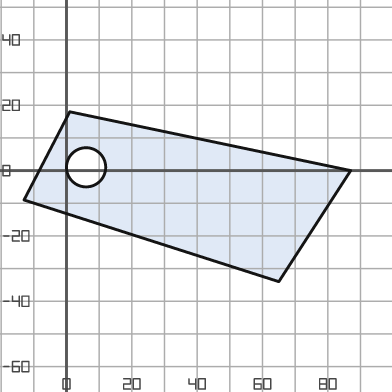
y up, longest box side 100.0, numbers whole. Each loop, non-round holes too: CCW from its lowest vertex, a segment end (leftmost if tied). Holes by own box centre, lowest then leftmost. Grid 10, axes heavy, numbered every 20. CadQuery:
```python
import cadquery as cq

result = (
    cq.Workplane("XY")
    .moveTo(65.0, -34.0)
    .lineTo(87.0, 0.0)
    .lineTo(1.0, 18.0)
    .lineTo(-13.0, -9.0)
    .close()
    .moveTo(6.0, 1.0)
    .circle(6.0)
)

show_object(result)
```